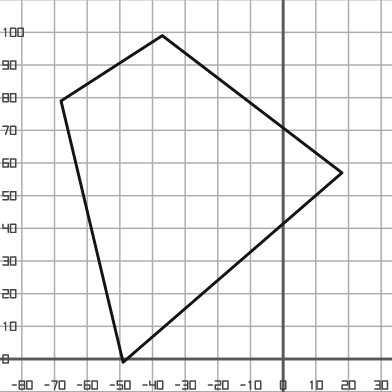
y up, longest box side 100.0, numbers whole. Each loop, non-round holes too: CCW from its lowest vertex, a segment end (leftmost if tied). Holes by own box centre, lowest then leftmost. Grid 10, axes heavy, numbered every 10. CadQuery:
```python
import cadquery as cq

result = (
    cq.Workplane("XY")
    .moveTo(-49.0, -1.0)
    .lineTo(18.0, 57.0)
    .lineTo(-37.0, 99.0)
    .lineTo(-68.0, 79.0)
    .close()
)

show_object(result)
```